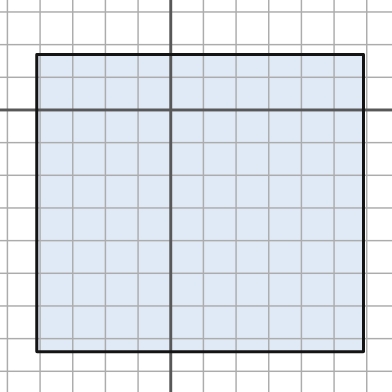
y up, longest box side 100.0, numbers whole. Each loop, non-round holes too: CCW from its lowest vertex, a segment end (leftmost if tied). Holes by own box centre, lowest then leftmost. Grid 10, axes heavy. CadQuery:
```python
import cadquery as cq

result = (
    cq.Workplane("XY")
    .moveTo(-41.0, -74.0)
    .lineTo(59.0, -74.0)
    .lineTo(59.0, 17.0)
    .lineTo(-41.0, 17.0)
    .close()
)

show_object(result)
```